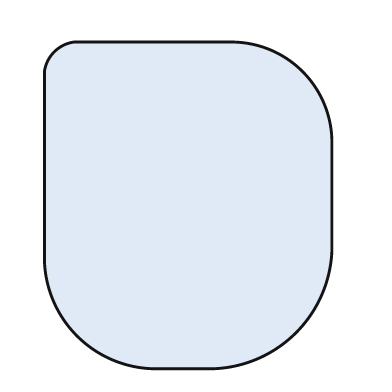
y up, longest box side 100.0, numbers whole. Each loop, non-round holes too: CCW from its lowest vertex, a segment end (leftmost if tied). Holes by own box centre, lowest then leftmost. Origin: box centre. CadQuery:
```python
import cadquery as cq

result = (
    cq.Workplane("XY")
    .moveTo(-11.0, -50.0)
    .lineTo(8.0, -50.0)
    .threePointArc((33.0, -39.0), (44.0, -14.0))
    .lineTo(44.0, 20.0)
    .threePointArc((35.0, 41.0), (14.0, 50.0))
    .lineTo(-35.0, 50.0)
    .threePointArc((-41.0, 47.0), (-44.0, 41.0))
    .lineTo(-44.0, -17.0)
    .threePointArc((-34.0, -40.0), (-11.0, -50.0))
    .close()
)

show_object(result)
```